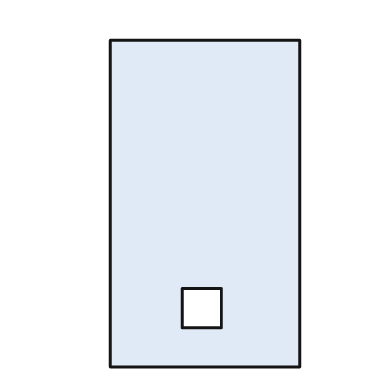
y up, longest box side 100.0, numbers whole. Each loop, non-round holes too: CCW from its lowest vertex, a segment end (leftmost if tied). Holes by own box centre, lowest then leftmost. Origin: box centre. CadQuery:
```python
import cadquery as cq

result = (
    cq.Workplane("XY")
    .moveTo(-29.0, -50.0)
    .lineTo(29.0, -50.0)
    .lineTo(29.0, 50.0)
    .lineTo(-29.0, 50.0)
    .close()
    .moveTo(-7.0, -38.0)
    .lineTo(5.0, -38.0)
    .lineTo(5.0, -26.0)
    .lineTo(-7.0, -26.0)
    .close()
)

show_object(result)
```